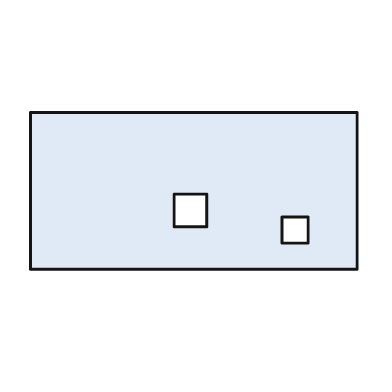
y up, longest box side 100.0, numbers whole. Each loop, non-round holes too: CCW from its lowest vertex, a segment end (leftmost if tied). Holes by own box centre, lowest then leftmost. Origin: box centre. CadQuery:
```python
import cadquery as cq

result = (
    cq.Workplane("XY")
    .moveTo(-50.0, -24.0)
    .lineTo(50.0, -24.0)
    .lineTo(50.0, 24.0)
    .lineTo(-50.0, 24.0)
    .close()
    .moveTo(27.0, -16.0)
    .lineTo(35.0, -16.0)
    .lineTo(35.0, -8.0)
    .lineTo(27.0, -8.0)
    .close()
    .moveTo(-6.0, -11.0)
    .lineTo(4.0, -11.0)
    .lineTo(4.0, -1.0)
    .lineTo(-6.0, -1.0)
    .close()
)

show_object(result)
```